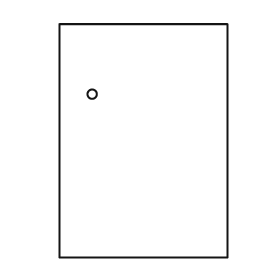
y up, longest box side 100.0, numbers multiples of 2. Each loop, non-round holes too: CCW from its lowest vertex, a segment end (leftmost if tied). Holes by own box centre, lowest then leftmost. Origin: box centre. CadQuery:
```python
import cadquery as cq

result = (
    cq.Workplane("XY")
    .moveTo(-36.0, -50.0)
    .lineTo(36.0, -50.0)
    .lineTo(36.0, 50.0)
    .lineTo(-36.0, 50.0)
    .close()
    .moveTo(-22.0, 20.0)
    .circle(2.0)
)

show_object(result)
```